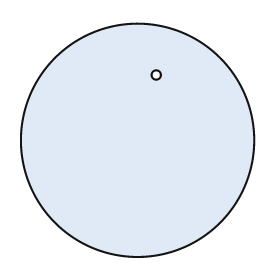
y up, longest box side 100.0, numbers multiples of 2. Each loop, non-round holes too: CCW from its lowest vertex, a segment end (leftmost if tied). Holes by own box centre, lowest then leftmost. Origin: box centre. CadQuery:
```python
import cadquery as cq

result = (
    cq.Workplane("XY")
    .moveTo(0.0, 0.0)
    .circle(50.0)
    .moveTo(8.0, 28.0)
    .circle(2.0)
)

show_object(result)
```